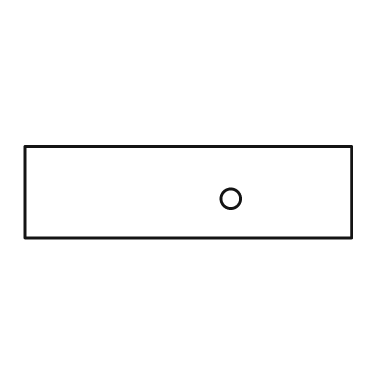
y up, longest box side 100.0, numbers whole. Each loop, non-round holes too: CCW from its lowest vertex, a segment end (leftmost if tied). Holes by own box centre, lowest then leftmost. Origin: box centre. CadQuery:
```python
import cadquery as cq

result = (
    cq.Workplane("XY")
    .moveTo(-50.0, -14.0)
    .lineTo(50.0, -14.0)
    .lineTo(50.0, 14.0)
    .lineTo(-50.0, 14.0)
    .close()
    .moveTo(13.0, -2.0)
    .circle(3.0)
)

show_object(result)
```